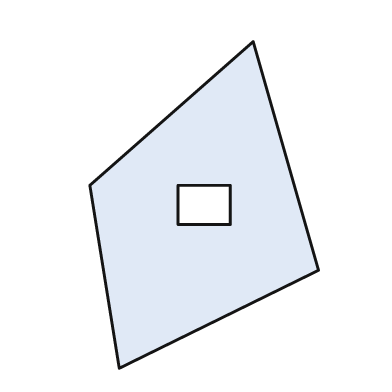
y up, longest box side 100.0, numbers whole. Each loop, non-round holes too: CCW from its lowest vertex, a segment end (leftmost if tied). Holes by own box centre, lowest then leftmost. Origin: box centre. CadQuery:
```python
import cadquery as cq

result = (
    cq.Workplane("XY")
    .moveTo(-26.0, -50.0)
    .lineTo(35.0, -20.0)
    .lineTo(15.0, 50.0)
    .lineTo(-35.0, 6.0)
    .close()
    .moveTo(-8.0, -6.0)
    .lineTo(8.0, -6.0)
    .lineTo(8.0, 6.0)
    .lineTo(-8.0, 6.0)
    .close()
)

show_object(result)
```